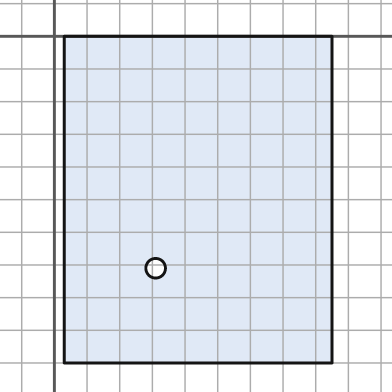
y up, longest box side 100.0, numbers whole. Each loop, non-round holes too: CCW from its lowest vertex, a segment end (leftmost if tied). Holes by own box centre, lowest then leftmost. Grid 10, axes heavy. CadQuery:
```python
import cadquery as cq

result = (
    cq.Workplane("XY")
    .moveTo(3.0, -100.0)
    .lineTo(85.0, -100.0)
    .lineTo(85.0, 0.0)
    .lineTo(3.0, 0.0)
    .close()
    .moveTo(31.0, -71.0)
    .circle(3.0)
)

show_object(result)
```